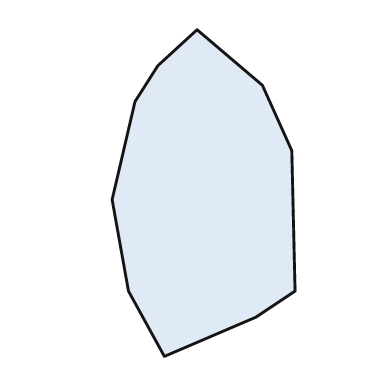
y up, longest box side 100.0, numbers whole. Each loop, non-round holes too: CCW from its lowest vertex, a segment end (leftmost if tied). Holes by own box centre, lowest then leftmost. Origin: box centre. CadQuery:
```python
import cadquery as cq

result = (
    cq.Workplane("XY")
    .moveTo(-12.0, -50.0)
    .lineTo(16.0, -38.0)
    .lineTo(28.0, -30.0)
    .lineTo(27.0, 13.0)
    .lineTo(18.0, 33.0)
    .lineTo(-2.0, 50.0)
    .lineTo(-14.0, 39.0)
    .lineTo(-21.0, 28.0)
    .lineTo(-28.0, -2.0)
    .lineTo(-23.0, -30.0)
    .close()
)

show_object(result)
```